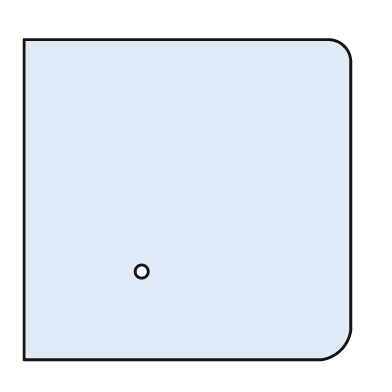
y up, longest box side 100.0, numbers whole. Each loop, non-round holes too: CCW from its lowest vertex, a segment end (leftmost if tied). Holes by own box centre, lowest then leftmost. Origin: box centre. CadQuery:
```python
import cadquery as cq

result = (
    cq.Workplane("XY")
    .moveTo(-50.0, -49.0)
    .lineTo(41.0, -49.0)
    .threePointArc((47.0, -46.0), (50.0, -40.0))
    .lineTo(50.0, 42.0)
    .threePointArc((48.0, 47.0), (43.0, 49.0))
    .lineTo(-50.0, 49.0)
    .close()
    .moveTo(-14.0, -22.0)
    .circle(2.0)
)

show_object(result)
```